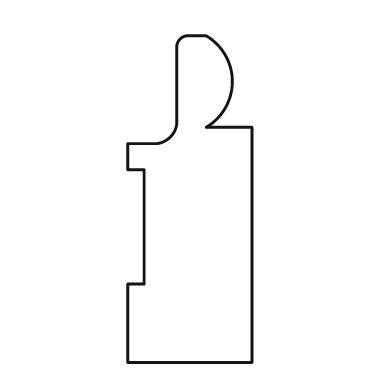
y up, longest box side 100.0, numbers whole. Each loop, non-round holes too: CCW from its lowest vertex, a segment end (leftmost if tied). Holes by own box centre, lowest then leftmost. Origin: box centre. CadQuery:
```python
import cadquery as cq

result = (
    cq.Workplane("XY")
    .moveTo(-19.0, -50.0)
    .lineTo(19.0, -50.0)
    .lineTo(19.0, 22.0)
    .lineTo(5.0, 22.0)
    .threePointArc((13.0, 36.0), (5.0, 50.0))
    .lineTo(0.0, 50.0)
    .threePointArc((-3.0, 49.0), (-4.0, 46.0))
    .lineTo(-4.0, 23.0)
    .threePointArc((-6.0, 19.0), (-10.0, 17.0))
    .lineTo(-19.0, 17.0)
    .lineTo(-19.0, 9.0)
    .lineTo(-14.0, 9.0)
    .lineTo(-14.0, -26.0)
    .lineTo(-19.0, -26.0)
    .close()
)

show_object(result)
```